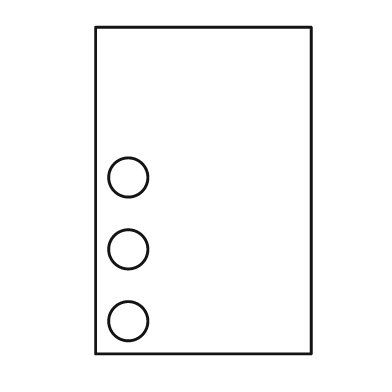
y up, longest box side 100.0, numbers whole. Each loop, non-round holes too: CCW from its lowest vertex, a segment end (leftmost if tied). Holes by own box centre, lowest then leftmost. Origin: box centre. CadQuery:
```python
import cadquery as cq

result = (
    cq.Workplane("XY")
    .moveTo(-33.0, -50.0)
    .lineTo(33.0, -50.0)
    .lineTo(33.0, 50.0)
    .lineTo(-33.0, 50.0)
    .close()
    .moveTo(-23.0, -40.0)
    .circle(6.0)
    .moveTo(-23.0, -18.0)
    .circle(6.0)
    .moveTo(-23.0, 4.0)
    .circle(6.0)
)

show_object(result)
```